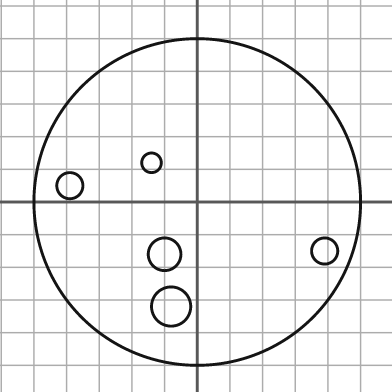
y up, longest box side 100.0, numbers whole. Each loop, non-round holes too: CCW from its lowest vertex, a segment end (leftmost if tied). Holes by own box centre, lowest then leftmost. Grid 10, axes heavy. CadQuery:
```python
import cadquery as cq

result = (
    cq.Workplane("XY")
    .moveTo(0.0, 0.0)
    .circle(50.0)
    .moveTo(-8.0, -32.0)
    .circle(6.0)
    .moveTo(-10.0, -16.0)
    .circle(5.0)
    .moveTo(39.0, -15.0)
    .circle(4.0)
    .moveTo(-39.0, 5.0)
    .circle(4.0)
    .moveTo(-14.0, 12.0)
    .circle(3.0)
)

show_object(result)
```